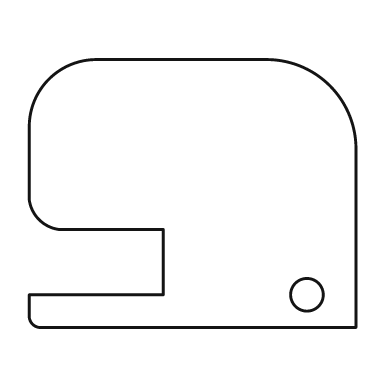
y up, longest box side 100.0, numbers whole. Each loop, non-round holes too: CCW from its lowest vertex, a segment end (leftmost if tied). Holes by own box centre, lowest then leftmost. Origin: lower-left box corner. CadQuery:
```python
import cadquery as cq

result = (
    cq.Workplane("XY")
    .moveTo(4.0, 0.0)
    .lineTo(100.0, 0.0)
    .lineTo(100.0, 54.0)
    .threePointArc((92.0, 74.0), (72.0, 82.0))
    .lineTo(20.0, 82.0)
    .threePointArc((6.0, 76.0), (0.0, 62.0))
    .lineTo(0.0, 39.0)
    .threePointArc((3.0, 33.0), (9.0, 30.0))
    .lineTo(41.0, 30.0)
    .lineTo(41.0, 10.0)
    .lineTo(0.0, 10.0)
    .lineTo(0.0, 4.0)
    .threePointArc((1.0, 1.0), (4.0, 0.0))
    .close()
    .moveTo(85.0, 10.0)
    .circle(5.0)
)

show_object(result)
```